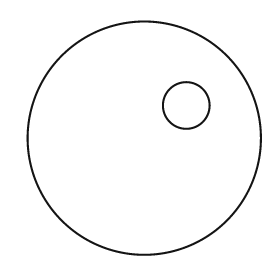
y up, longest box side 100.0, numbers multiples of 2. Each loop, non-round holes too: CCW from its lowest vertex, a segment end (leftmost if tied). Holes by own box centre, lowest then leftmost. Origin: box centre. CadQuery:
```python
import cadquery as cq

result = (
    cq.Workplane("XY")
    .moveTo(0.0, 0.0)
    .circle(50.0)
    .moveTo(18.0, 14.0)
    .circle(10.0)
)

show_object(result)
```